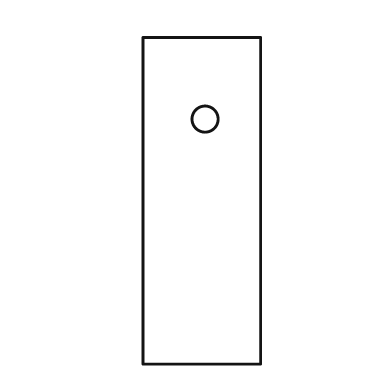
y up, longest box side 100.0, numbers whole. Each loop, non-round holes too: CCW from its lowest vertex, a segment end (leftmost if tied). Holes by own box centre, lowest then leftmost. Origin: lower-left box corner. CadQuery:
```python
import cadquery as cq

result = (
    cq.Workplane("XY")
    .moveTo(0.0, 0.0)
    .lineTo(36.0, 0.0)
    .lineTo(36.0, 100.0)
    .lineTo(0.0, 100.0)
    .close()
    .moveTo(19.0, 75.0)
    .circle(4.0)
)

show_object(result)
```